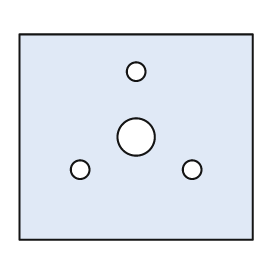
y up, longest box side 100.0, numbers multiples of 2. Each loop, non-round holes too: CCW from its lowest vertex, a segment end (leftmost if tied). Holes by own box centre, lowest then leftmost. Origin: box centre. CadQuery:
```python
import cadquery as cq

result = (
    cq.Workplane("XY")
    .moveTo(-50.0, -44.0)
    .lineTo(50.0, -44.0)
    .lineTo(50.0, 44.0)
    .lineTo(-50.0, 44.0)
    .close()
    .moveTo(-24.0, -14.0)
    .circle(4.0)
    .moveTo(24.0, -14.0)
    .circle(4.0)
    .moveTo(0.0, 0.0)
    .circle(8.0)
    .moveTo(0.0, 28.0)
    .circle(4.0)
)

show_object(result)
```